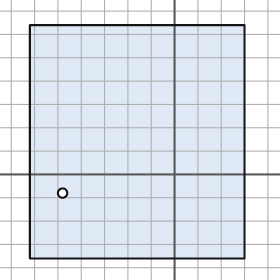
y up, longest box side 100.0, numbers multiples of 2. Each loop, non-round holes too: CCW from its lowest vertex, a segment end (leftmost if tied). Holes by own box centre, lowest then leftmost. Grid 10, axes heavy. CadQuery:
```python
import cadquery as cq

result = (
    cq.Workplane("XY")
    .moveTo(-62.0, -36.0)
    .lineTo(30.0, -36.0)
    .lineTo(30.0, 64.0)
    .lineTo(-62.0, 64.0)
    .close()
    .moveTo(-48.0, -8.0)
    .circle(2.0)
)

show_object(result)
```